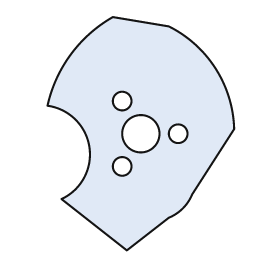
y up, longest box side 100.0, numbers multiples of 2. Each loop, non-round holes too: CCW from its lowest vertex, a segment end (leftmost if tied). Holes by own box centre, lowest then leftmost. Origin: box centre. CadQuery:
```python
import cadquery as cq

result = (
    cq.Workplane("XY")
    .moveTo(-6.0, -50.0)
    .lineTo(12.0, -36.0)
    .threePointArc((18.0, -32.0), (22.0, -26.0))
    .lineTo(40.0, 2.0)
    .threePointArc((32.0, 28.0), (12.0, 46.0))
    .lineTo(-12.0, 50.0)
    .threePointArc((-30.0, 34.0), (-40.0, 12.0))
    .threePointArc((-22.0, -6.0), (-34.0, -28.0))
    .close()
    .moveTo(-8.0, -14.0)
    .circle(4.0)
    .moveTo(0.0, 0.0)
    .circle(8.0)
    .moveTo(16.0, 0.0)
    .circle(4.0)
    .moveTo(-8.0, 14.0)
    .circle(4.0)
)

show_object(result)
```